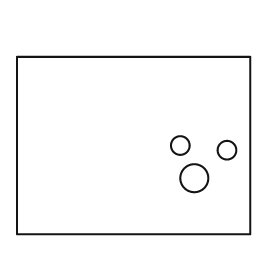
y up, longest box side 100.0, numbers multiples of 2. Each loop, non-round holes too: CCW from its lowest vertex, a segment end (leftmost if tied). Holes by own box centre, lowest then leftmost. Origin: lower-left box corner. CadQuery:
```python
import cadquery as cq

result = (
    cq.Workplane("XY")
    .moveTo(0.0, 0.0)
    .lineTo(100.0, 0.0)
    .lineTo(100.0, 76.0)
    .lineTo(0.0, 76.0)
    .close()
    .moveTo(76.0, 24.0)
    .circle(6.0)
    .moveTo(90.0, 36.0)
    .circle(4.0)
    .moveTo(70.0, 38.0)
    .circle(4.0)
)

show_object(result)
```